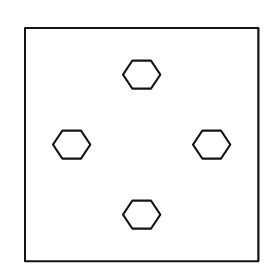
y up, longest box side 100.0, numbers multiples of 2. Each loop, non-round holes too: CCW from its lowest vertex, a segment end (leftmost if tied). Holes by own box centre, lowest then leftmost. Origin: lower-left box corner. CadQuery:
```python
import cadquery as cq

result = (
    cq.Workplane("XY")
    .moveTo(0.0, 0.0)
    .lineTo(100.0, 0.0)
    .lineTo(100.0, 100.0)
    .lineTo(0.0, 100.0)
    .close()
    .moveTo(46.0, 14.0)
    .lineTo(54.0, 14.0)
    .lineTo(58.0, 20.0)
    .lineTo(54.0, 26.0)
    .lineTo(46.0, 26.0)
    .lineTo(42.0, 20.0)
    .close()
    .moveTo(16.0, 44.0)
    .lineTo(24.0, 44.0)
    .lineTo(28.0, 50.0)
    .lineTo(24.0, 56.0)
    .lineTo(16.0, 56.0)
    .lineTo(12.0, 50.0)
    .close()
    .moveTo(76.0, 44.0)
    .lineTo(84.0, 44.0)
    .lineTo(88.0, 50.0)
    .lineTo(84.0, 56.0)
    .lineTo(76.0, 56.0)
    .lineTo(72.0, 50.0)
    .close()
    .moveTo(46.0, 74.0)
    .lineTo(54.0, 74.0)
    .lineTo(58.0, 80.0)
    .lineTo(54.0, 86.0)
    .lineTo(46.0, 86.0)
    .lineTo(42.0, 80.0)
    .close()
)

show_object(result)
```